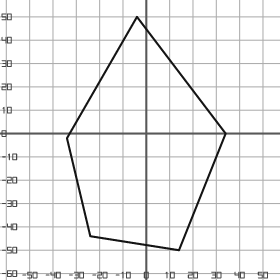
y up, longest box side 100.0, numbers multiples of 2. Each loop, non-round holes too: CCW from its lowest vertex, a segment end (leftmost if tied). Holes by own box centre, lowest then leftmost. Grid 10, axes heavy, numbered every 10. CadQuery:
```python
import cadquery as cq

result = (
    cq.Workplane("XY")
    .moveTo(14.0, -50.0)
    .lineTo(34.0, 0.0)
    .lineTo(-4.0, 50.0)
    .lineTo(-34.0, -2.0)
    .lineTo(-24.0, -44.0)
    .close()
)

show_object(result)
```